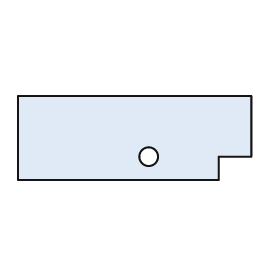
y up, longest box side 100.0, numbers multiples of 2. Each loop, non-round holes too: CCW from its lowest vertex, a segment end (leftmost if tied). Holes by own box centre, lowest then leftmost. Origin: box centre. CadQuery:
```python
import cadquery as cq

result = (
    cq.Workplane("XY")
    .moveTo(-50.0, -18.0)
    .lineTo(36.0, -18.0)
    .lineTo(36.0, -8.0)
    .lineTo(50.0, -8.0)
    .lineTo(50.0, 18.0)
    .lineTo(-50.0, 18.0)
    .close()
    .moveTo(6.0, -8.0)
    .circle(4.0)
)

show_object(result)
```